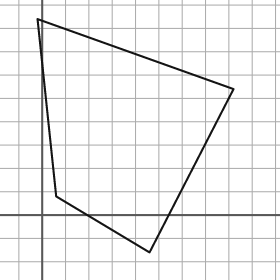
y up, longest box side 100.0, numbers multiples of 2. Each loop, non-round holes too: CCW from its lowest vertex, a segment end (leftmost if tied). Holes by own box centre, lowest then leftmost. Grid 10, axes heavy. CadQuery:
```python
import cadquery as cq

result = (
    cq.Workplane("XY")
    .moveTo(46.0, -16.0)
    .lineTo(82.0, 54.0)
    .lineTo(-2.0, 84.0)
    .lineTo(6.0, 8.0)
    .close()
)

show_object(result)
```